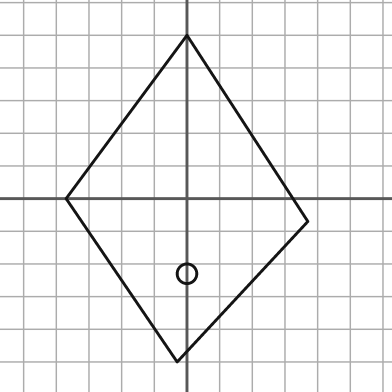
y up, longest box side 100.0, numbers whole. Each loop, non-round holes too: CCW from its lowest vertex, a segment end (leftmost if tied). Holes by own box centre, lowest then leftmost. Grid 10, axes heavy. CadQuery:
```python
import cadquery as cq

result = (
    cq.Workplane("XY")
    .moveTo(-3.0, -50.0)
    .lineTo(37.0, -7.0)
    .lineTo(0.0, 50.0)
    .lineTo(-37.0, 0.0)
    .close()
    .moveTo(0.0, -23.0)
    .circle(3.0)
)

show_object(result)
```